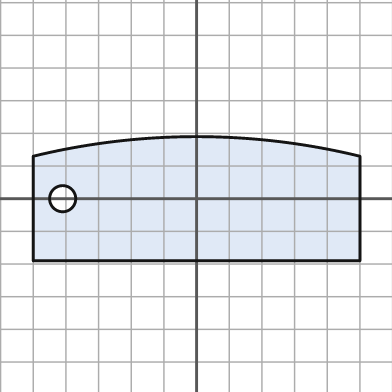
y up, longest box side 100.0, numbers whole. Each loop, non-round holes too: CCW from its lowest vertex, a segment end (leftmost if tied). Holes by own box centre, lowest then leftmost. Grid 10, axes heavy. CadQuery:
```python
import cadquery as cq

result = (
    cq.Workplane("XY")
    .moveTo(-50.0, -19.0)
    .lineTo(50.0, -19.0)
    .lineTo(50.0, 13.0)
    .threePointArc((0.0, 19.0), (-50.0, 13.0))
    .close()
    .moveTo(-41.0, 0.0)
    .circle(4.0)
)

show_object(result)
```